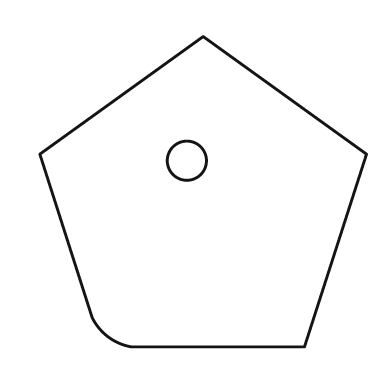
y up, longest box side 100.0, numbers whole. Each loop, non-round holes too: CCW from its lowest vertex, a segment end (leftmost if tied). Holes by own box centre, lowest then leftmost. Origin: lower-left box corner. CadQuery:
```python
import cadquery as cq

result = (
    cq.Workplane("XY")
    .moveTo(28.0, 0.0)
    .lineTo(81.0, 0.0)
    .lineTo(100.0, 59.0)
    .lineTo(50.0, 95.0)
    .lineTo(0.0, 59.0)
    .lineTo(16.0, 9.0)
    .threePointArc((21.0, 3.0), (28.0, 0.0))
    .close()
    .moveTo(45.0, 57.0)
    .circle(6.0)
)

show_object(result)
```